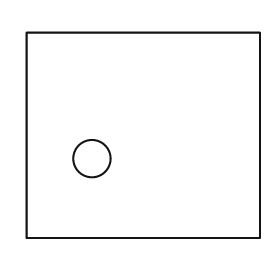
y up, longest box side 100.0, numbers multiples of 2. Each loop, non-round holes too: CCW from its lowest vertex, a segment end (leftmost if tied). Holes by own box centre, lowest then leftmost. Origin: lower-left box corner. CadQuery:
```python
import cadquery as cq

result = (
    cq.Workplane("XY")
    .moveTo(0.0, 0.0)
    .lineTo(100.0, 0.0)
    .lineTo(100.0, 88.0)
    .lineTo(0.0, 88.0)
    .close()
    .moveTo(28.0, 34.0)
    .circle(8.0)
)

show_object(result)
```